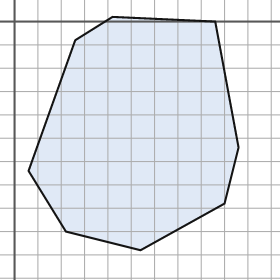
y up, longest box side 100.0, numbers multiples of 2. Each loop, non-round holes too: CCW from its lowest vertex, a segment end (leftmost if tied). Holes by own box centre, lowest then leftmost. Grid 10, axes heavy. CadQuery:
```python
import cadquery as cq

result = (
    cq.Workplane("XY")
    .moveTo(54.0, -98.0)
    .lineTo(90.0, -78.0)
    .lineTo(96.0, -54.0)
    .lineTo(86.0, 0.0)
    .lineTo(42.0, 2.0)
    .lineTo(26.0, -8.0)
    .lineTo(6.0, -64.0)
    .lineTo(22.0, -90.0)
    .close()
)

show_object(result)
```